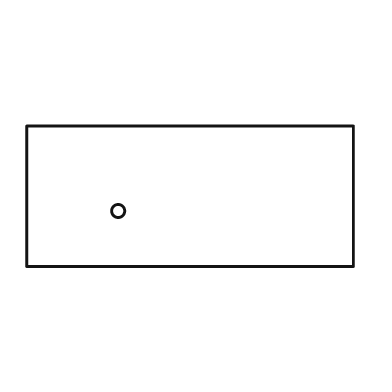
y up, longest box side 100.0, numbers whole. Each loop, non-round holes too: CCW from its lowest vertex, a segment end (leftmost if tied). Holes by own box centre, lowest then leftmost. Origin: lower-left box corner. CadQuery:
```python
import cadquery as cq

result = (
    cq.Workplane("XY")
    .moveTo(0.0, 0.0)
    .lineTo(100.0, 0.0)
    .lineTo(100.0, 43.0)
    .lineTo(0.0, 43.0)
    .close()
    .moveTo(28.0, 17.0)
    .circle(2.0)
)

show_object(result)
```